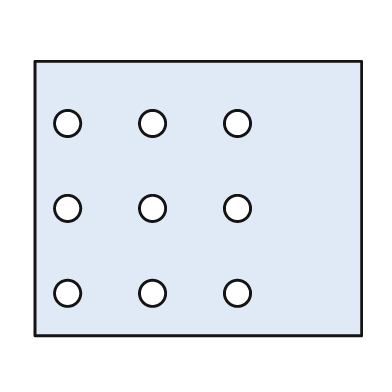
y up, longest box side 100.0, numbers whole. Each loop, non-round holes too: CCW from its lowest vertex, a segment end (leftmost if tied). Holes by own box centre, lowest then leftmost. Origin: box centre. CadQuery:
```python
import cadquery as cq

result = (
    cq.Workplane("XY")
    .moveTo(-50.0, -42.0)
    .lineTo(50.0, -42.0)
    .lineTo(50.0, 42.0)
    .lineTo(-50.0, 42.0)
    .close()
    .moveTo(-40.0, -29.0)
    .circle(4.0)
    .moveTo(-14.0, -29.0)
    .circle(4.0)
    .moveTo(12.0, -29.0)
    .circle(4.0)
    .moveTo(-40.0, -3.0)
    .circle(4.0)
    .moveTo(-14.0, -3.0)
    .circle(4.0)
    .moveTo(12.0, -3.0)
    .circle(4.0)
    .moveTo(-40.0, 23.0)
    .circle(4.0)
    .moveTo(-14.0, 23.0)
    .circle(4.0)
    .moveTo(12.0, 23.0)
    .circle(4.0)
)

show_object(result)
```